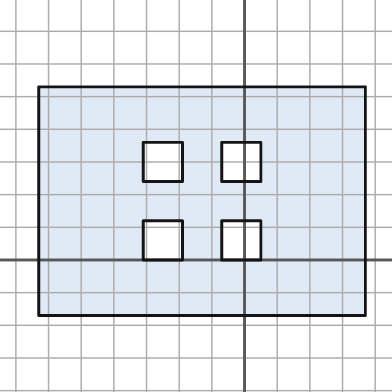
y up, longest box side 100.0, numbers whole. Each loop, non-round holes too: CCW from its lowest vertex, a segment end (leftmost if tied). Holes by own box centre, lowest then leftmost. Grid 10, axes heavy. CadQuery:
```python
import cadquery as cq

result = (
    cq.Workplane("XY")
    .moveTo(-63.0, -17.0)
    .lineTo(37.0, -17.0)
    .lineTo(37.0, 53.0)
    .lineTo(-63.0, 53.0)
    .close()
    .moveTo(-31.0, 0.0)
    .lineTo(-19.0, 0.0)
    .lineTo(-19.0, 12.0)
    .lineTo(-31.0, 12.0)
    .close()
    .moveTo(-7.0, 0.0)
    .lineTo(5.0, 0.0)
    .lineTo(5.0, 12.0)
    .lineTo(-7.0, 12.0)
    .close()
    .moveTo(-31.0, 24.0)
    .lineTo(-19.0, 24.0)
    .lineTo(-19.0, 36.0)
    .lineTo(-31.0, 36.0)
    .close()
    .moveTo(-7.0, 24.0)
    .lineTo(5.0, 24.0)
    .lineTo(5.0, 36.0)
    .lineTo(-7.0, 36.0)
    .close()
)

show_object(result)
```